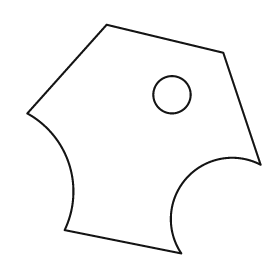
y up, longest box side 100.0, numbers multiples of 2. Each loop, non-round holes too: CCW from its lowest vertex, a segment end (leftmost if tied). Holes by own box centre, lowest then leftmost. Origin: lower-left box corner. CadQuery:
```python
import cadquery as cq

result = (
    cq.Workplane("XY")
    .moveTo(66.0, 0.0)
    .threePointArc((68.0, 32.0), (100.0, 38.0))
    .lineTo(84.0, 86.0)
    .lineTo(34.0, 98.0)
    .lineTo(0.0, 60.0)
    .threePointArc((18.0, 38.0), (16.0, 10.0))
    .close()
    .moveTo(62.0, 68.0)
    .circle(8.0)
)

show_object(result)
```